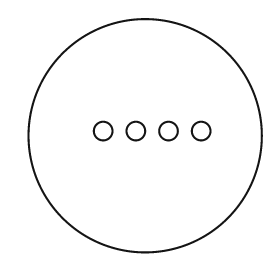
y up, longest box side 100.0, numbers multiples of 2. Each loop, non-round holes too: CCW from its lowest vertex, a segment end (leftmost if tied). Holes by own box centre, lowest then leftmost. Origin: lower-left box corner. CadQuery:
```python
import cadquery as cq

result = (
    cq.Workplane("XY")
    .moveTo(50.0, 50.0)
    .circle(50.0)
    .moveTo(32.0, 52.0)
    .circle(4.0)
    .moveTo(46.0, 52.0)
    .circle(4.0)
    .moveTo(60.0, 52.0)
    .circle(4.0)
    .moveTo(74.0, 52.0)
    .circle(4.0)
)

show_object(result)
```